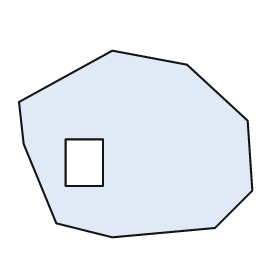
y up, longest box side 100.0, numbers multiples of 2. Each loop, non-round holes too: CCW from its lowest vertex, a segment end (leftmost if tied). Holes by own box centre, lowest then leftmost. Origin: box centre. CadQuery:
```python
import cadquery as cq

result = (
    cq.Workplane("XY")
    .moveTo(-10.0, -40.0)
    .lineTo(34.0, -36.0)
    .lineTo(50.0, -20.0)
    .lineTo(48.0, 10.0)
    .lineTo(22.0, 34.0)
    .lineTo(-10.0, 40.0)
    .lineTo(-50.0, 18.0)
    .lineTo(-48.0, 0.0)
    .lineTo(-34.0, -34.0)
    .close()
    .moveTo(-30.0, -18.0)
    .lineTo(-14.0, -18.0)
    .lineTo(-14.0, 2.0)
    .lineTo(-30.0, 2.0)
    .close()
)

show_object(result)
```